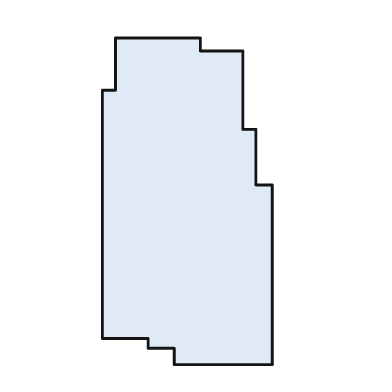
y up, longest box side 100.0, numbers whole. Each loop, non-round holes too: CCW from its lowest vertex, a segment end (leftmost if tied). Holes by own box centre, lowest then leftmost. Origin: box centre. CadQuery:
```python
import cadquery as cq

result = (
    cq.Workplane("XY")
    .moveTo(-4.0, -50.0)
    .lineTo(26.0, -50.0)
    .lineTo(26.0, 5.0)
    .lineTo(21.0, 5.0)
    .lineTo(21.0, 22.0)
    .lineTo(17.0, 22.0)
    .lineTo(17.0, 46.0)
    .lineTo(4.0, 46.0)
    .lineTo(4.0, 50.0)
    .lineTo(-22.0, 50.0)
    .lineTo(-22.0, 34.0)
    .lineTo(-26.0, 34.0)
    .lineTo(-26.0, -42.0)
    .lineTo(-12.0, -42.0)
    .lineTo(-12.0, -45.0)
    .lineTo(-4.0, -45.0)
    .close()
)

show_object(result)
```